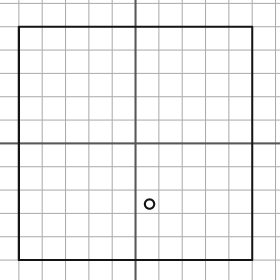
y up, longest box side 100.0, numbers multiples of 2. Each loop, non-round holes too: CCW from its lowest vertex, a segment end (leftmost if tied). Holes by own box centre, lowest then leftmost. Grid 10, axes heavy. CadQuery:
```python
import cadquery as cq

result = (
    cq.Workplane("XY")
    .moveTo(-50.0, -50.0)
    .lineTo(50.0, -50.0)
    .lineTo(50.0, 50.0)
    .lineTo(-50.0, 50.0)
    .close()
    .moveTo(6.0, -26.0)
    .circle(2.0)
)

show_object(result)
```